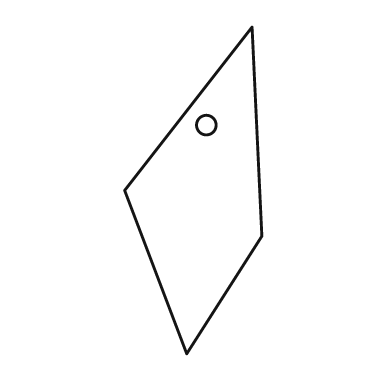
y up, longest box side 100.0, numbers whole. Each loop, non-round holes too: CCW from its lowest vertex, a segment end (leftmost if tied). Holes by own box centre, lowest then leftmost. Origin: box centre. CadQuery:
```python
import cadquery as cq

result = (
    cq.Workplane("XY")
    .moveTo(-2.0, -50.0)
    .lineTo(21.0, -14.0)
    .lineTo(18.0, 50.0)
    .lineTo(-21.0, 0.0)
    .close()
    .moveTo(4.0, 20.0)
    .circle(3.0)
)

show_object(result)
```